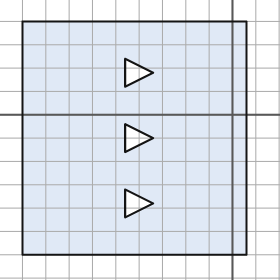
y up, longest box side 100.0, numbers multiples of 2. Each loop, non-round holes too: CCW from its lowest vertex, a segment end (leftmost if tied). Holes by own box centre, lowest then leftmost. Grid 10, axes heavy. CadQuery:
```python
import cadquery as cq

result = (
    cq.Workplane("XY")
    .moveTo(-90.0, -60.0)
    .lineTo(6.0, -60.0)
    .lineTo(6.0, 40.0)
    .lineTo(-90.0, 40.0)
    .close()
    .moveTo(-46.0, -44.0)
    .lineTo(-34.0, -38.0)
    .lineTo(-46.0, -32.0)
    .close()
    .moveTo(-46.0, -16.0)
    .lineTo(-34.0, -10.0)
    .lineTo(-46.0, -4.0)
    .close()
    .moveTo(-46.0, 12.0)
    .lineTo(-34.0, 18.0)
    .lineTo(-46.0, 24.0)
    .close()
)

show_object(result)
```